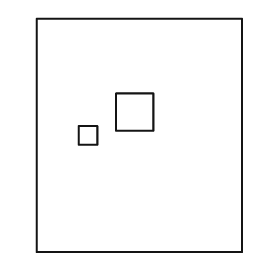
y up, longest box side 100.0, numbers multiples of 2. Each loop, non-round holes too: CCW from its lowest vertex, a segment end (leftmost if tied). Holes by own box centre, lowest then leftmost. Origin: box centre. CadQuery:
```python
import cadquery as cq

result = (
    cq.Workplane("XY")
    .moveTo(-44.0, -50.0)
    .lineTo(44.0, -50.0)
    .lineTo(44.0, 50.0)
    .lineTo(-44.0, 50.0)
    .close()
    .moveTo(-26.0, -4.0)
    .lineTo(-18.0, -4.0)
    .lineTo(-18.0, 4.0)
    .lineTo(-26.0, 4.0)
    .close()
    .moveTo(-10.0, 2.0)
    .lineTo(6.0, 2.0)
    .lineTo(6.0, 18.0)
    .lineTo(-10.0, 18.0)
    .close()
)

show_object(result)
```